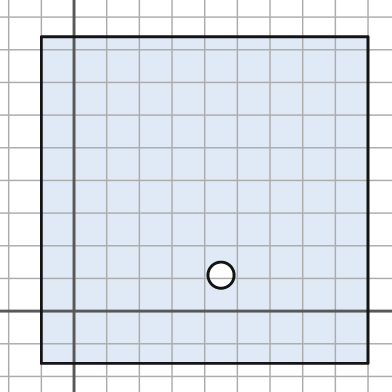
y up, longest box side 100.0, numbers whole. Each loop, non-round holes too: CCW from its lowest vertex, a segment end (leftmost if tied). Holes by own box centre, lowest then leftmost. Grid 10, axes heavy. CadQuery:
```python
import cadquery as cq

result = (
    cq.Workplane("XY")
    .moveTo(-10.0, -16.0)
    .lineTo(90.0, -16.0)
    .lineTo(90.0, 84.0)
    .lineTo(-10.0, 84.0)
    .close()
    .moveTo(45.0, 11.0)
    .circle(4.0)
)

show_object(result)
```